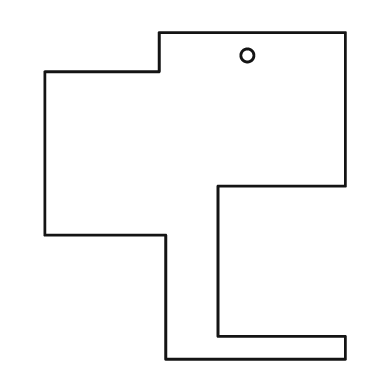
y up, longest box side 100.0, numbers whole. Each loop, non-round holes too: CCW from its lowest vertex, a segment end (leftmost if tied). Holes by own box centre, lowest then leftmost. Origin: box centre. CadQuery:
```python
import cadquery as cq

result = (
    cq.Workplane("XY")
    .moveTo(-9.0, -50.0)
    .lineTo(46.0, -50.0)
    .lineTo(46.0, -43.0)
    .lineTo(7.0, -43.0)
    .lineTo(7.0, 3.0)
    .lineTo(46.0, 3.0)
    .lineTo(46.0, 50.0)
    .lineTo(-11.0, 50.0)
    .lineTo(-11.0, 38.0)
    .lineTo(-46.0, 38.0)
    .lineTo(-46.0, -12.0)
    .lineTo(-9.0, -12.0)
    .close()
    .moveTo(16.0, 43.0)
    .circle(2.0)
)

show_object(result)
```